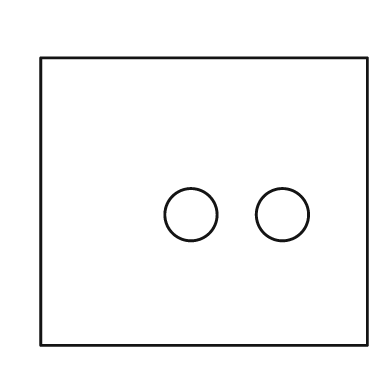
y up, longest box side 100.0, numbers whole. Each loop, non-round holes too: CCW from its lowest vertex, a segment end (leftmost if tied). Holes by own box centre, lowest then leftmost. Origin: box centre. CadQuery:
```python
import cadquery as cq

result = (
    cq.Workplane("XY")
    .moveTo(-50.0, -44.0)
    .lineTo(50.0, -44.0)
    .lineTo(50.0, 44.0)
    .lineTo(-50.0, 44.0)
    .close()
    .moveTo(-4.0, -4.0)
    .circle(8.0)
    .moveTo(24.0, -4.0)
    .circle(8.0)
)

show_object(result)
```